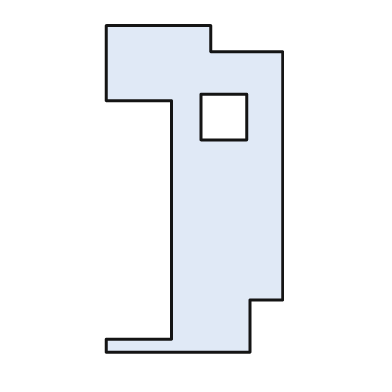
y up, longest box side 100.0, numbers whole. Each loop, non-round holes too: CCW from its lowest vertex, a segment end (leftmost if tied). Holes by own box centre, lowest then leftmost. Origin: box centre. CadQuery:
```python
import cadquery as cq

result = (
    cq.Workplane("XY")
    .moveTo(-27.0, -50.0)
    .lineTo(17.0, -50.0)
    .lineTo(17.0, -34.0)
    .lineTo(27.0, -34.0)
    .lineTo(27.0, 42.0)
    .lineTo(5.0, 42.0)
    .lineTo(5.0, 50.0)
    .lineTo(-27.0, 50.0)
    .lineTo(-27.0, 27.0)
    .lineTo(-7.0, 27.0)
    .lineTo(-7.0, -46.0)
    .lineTo(-27.0, -46.0)
    .close()
    .moveTo(2.0, 15.0)
    .lineTo(16.0, 15.0)
    .lineTo(16.0, 29.0)
    .lineTo(2.0, 29.0)
    .close()
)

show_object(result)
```